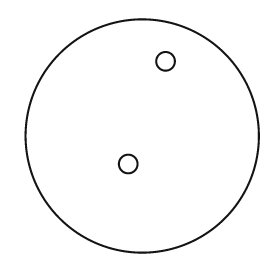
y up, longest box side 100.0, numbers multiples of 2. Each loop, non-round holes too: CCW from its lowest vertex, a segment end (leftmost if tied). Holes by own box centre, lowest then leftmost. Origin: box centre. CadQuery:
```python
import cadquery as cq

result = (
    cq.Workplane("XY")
    .moveTo(0.0, 0.0)
    .circle(50.0)
    .moveTo(-6.0, -12.0)
    .circle(4.0)
    .moveTo(10.0, 32.0)
    .circle(4.0)
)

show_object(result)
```